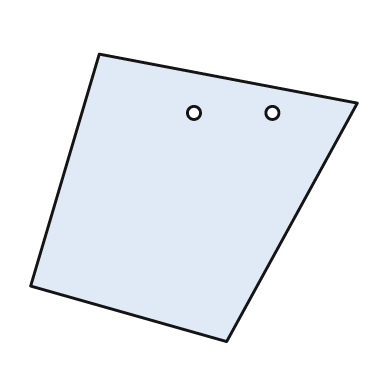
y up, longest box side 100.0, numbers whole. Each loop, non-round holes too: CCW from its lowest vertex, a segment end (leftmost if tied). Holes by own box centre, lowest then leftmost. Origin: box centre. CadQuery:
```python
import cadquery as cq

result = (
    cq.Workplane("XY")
    .moveTo(10.0, -44.0)
    .lineTo(50.0, 29.0)
    .lineTo(-29.0, 44.0)
    .lineTo(-50.0, -27.0)
    .close()
    .moveTo(0.0, 26.0)
    .circle(2.0)
    .moveTo(24.0, 26.0)
    .circle(2.0)
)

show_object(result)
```